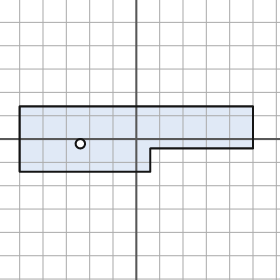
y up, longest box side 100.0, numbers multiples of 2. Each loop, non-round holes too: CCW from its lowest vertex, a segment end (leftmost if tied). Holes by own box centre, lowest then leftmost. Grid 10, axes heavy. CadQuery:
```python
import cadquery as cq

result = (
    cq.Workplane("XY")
    .moveTo(-50.0, -14.0)
    .lineTo(6.0, -14.0)
    .lineTo(6.0, -4.0)
    .lineTo(50.0, -4.0)
    .lineTo(50.0, 14.0)
    .lineTo(-50.0, 14.0)
    .close()
    .moveTo(-24.0, -2.0)
    .circle(2.0)
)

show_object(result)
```